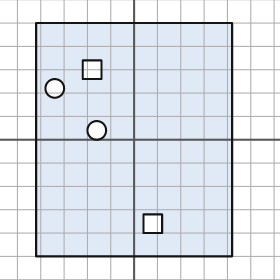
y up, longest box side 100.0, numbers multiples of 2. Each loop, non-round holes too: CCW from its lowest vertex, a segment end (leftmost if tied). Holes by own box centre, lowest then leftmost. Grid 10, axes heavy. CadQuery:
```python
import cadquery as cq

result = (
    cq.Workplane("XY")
    .moveTo(-42.0, -50.0)
    .lineTo(42.0, -50.0)
    .lineTo(42.0, 50.0)
    .lineTo(-42.0, 50.0)
    .close()
    .moveTo(4.0, -40.0)
    .lineTo(12.0, -40.0)
    .lineTo(12.0, -32.0)
    .lineTo(4.0, -32.0)
    .close()
    .moveTo(-16.0, 4.0)
    .circle(4.0)
    .moveTo(-34.0, 22.0)
    .circle(4.0)
    .moveTo(-22.0, 26.0)
    .lineTo(-14.0, 26.0)
    .lineTo(-14.0, 34.0)
    .lineTo(-22.0, 34.0)
    .close()
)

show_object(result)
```